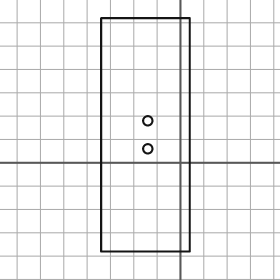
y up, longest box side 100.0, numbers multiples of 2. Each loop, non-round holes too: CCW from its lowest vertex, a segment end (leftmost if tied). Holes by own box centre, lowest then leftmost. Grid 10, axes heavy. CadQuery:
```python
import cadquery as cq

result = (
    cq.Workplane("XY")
    .moveTo(-34.0, -38.0)
    .lineTo(4.0, -38.0)
    .lineTo(4.0, 62.0)
    .lineTo(-34.0, 62.0)
    .close()
    .moveTo(-14.0, 6.0)
    .circle(2.0)
    .moveTo(-14.0, 18.0)
    .circle(2.0)
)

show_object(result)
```